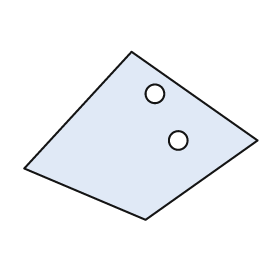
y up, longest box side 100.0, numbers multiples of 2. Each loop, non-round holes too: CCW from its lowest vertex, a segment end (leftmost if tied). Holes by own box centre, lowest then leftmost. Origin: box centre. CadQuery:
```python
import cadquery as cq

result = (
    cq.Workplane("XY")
    .moveTo(2.0, -36.0)
    .lineTo(50.0, -2.0)
    .lineTo(-4.0, 36.0)
    .lineTo(-50.0, -14.0)
    .close()
    .moveTo(16.0, -2.0)
    .circle(4.0)
    .moveTo(6.0, 18.0)
    .circle(4.0)
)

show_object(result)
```